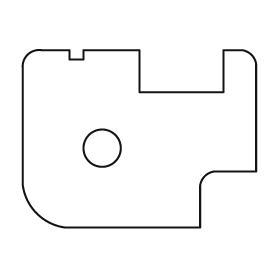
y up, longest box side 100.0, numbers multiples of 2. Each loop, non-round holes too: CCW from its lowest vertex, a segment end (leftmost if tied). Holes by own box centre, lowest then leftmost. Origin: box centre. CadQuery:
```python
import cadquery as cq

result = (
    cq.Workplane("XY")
    .moveTo(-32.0, -38.0)
    .lineTo(26.0, -38.0)
    .lineTo(26.0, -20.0)
    .threePointArc((28.0, -16.0), (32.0, -14.0))
    .lineTo(50.0, -14.0)
    .lineTo(50.0, 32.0)
    .threePointArc((48.0, 36.0), (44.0, 38.0))
    .lineTo(36.0, 38.0)
    .lineTo(36.0, 20.0)
    .lineTo(0.0, 20.0)
    .lineTo(0.0, 38.0)
    .lineTo(-24.0, 38.0)
    .lineTo(-24.0, 34.0)
    .lineTo(-30.0, 34.0)
    .lineTo(-30.0, 38.0)
    .lineTo(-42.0, 38.0)
    .threePointArc((-48.0, 36.0), (-50.0, 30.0))
    .lineTo(-50.0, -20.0)
    .threePointArc((-44.0, -32.0), (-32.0, -38.0))
    .close()
    .moveTo(-16.0, -4.0)
    .circle(8.0)
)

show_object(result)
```